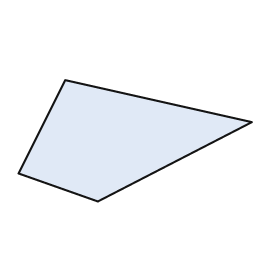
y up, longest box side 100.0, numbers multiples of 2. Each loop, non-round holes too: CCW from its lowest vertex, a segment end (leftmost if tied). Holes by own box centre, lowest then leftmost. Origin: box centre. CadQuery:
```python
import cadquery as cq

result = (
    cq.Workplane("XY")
    .moveTo(-16.0, -26.0)
    .lineTo(50.0, 8.0)
    .lineTo(-30.0, 26.0)
    .lineTo(-50.0, -14.0)
    .close()
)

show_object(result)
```